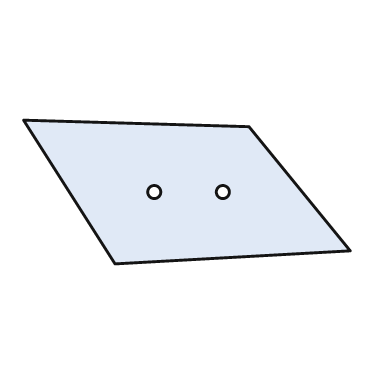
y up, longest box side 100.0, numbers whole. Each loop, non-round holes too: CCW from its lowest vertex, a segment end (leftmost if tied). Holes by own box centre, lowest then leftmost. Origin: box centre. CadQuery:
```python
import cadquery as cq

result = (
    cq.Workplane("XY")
    .moveTo(-22.0, -22.0)
    .lineTo(50.0, -18.0)
    .lineTo(19.0, 20.0)
    .lineTo(-50.0, 22.0)
    .close()
    .moveTo(-10.0, 0.0)
    .circle(2.0)
    .moveTo(11.0, 0.0)
    .circle(2.0)
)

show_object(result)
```